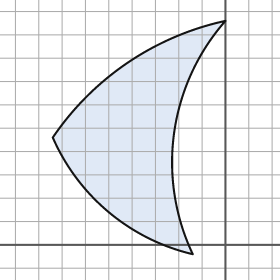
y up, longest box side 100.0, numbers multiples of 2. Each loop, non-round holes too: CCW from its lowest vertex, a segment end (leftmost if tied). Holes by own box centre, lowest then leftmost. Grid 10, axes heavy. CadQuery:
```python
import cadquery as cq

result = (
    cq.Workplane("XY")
    .moveTo(-14.0, -4.0)
    .threePointArc((-22.0, 48.0), (0.0, 96.0))
    .threePointArc((-42.0, 78.0), (-74.0, 46.0))
    .threePointArc((-50.0, 14.0), (-14.0, -4.0))
    .close()
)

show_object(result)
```